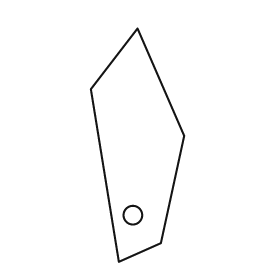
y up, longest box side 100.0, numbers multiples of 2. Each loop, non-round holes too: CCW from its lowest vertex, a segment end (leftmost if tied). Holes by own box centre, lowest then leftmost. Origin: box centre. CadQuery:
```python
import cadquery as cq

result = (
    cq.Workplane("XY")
    .moveTo(-8.0, -50.0)
    .lineTo(10.0, -42.0)
    .lineTo(20.0, 4.0)
    .lineTo(0.0, 50.0)
    .lineTo(-20.0, 24.0)
    .close()
    .moveTo(-2.0, -30.0)
    .circle(4.0)
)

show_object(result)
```